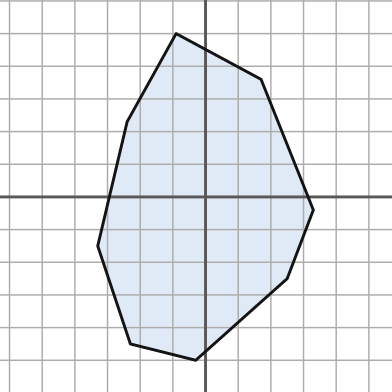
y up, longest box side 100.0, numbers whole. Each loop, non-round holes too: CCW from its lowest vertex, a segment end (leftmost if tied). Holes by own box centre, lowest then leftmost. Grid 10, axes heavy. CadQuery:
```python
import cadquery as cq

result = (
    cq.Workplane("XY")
    .moveTo(-3.0, -50.0)
    .lineTo(25.0, -25.0)
    .lineTo(33.0, -4.0)
    .lineTo(17.0, 36.0)
    .lineTo(-9.0, 50.0)
    .lineTo(-24.0, 23.0)
    .lineTo(-33.0, -15.0)
    .lineTo(-23.0, -45.0)
    .close()
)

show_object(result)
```